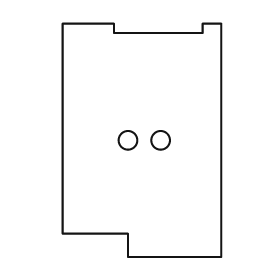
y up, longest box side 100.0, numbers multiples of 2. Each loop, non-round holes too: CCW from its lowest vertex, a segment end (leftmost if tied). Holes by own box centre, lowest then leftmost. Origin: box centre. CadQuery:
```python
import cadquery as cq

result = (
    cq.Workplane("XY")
    .moveTo(-6.0, -50.0)
    .lineTo(34.0, -50.0)
    .lineTo(34.0, 50.0)
    .lineTo(26.0, 50.0)
    .lineTo(26.0, 46.0)
    .lineTo(-12.0, 46.0)
    .lineTo(-12.0, 50.0)
    .lineTo(-34.0, 50.0)
    .lineTo(-34.0, -40.0)
    .lineTo(-6.0, -40.0)
    .close()
    .moveTo(-6.0, 0.0)
    .circle(4.0)
    .moveTo(8.0, 0.0)
    .circle(4.0)
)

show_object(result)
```